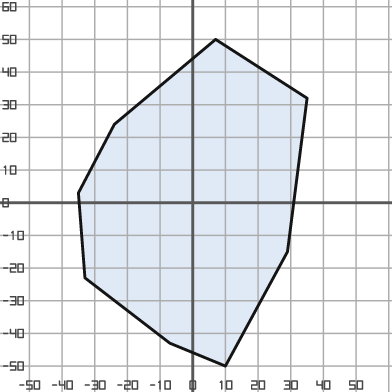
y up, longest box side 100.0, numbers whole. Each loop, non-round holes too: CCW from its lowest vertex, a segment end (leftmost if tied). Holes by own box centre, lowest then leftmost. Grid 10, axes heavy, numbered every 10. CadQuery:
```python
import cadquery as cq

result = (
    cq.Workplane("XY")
    .moveTo(10.0, -50.0)
    .lineTo(29.0, -15.0)
    .lineTo(35.0, 32.0)
    .lineTo(7.0, 50.0)
    .lineTo(-24.0, 24.0)
    .lineTo(-35.0, 3.0)
    .lineTo(-33.0, -23.0)
    .lineTo(-7.0, -43.0)
    .close()
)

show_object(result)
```